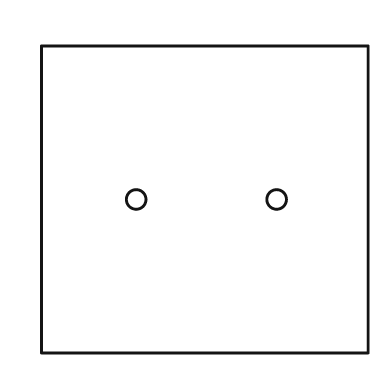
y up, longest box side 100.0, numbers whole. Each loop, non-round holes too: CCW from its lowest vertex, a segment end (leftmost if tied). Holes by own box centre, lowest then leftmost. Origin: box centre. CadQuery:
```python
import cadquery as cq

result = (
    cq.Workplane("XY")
    .moveTo(-50.0, -47.0)
    .lineTo(50.0, -47.0)
    .lineTo(50.0, 47.0)
    .lineTo(-50.0, 47.0)
    .close()
    .moveTo(-21.0, 0.0)
    .circle(3.0)
    .moveTo(22.0, 0.0)
    .circle(3.0)
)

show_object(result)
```